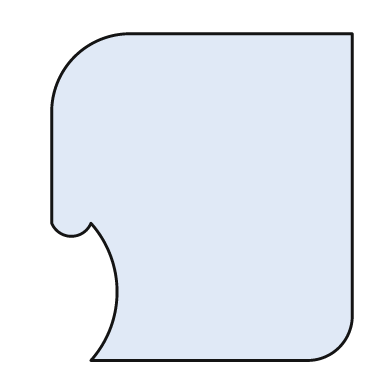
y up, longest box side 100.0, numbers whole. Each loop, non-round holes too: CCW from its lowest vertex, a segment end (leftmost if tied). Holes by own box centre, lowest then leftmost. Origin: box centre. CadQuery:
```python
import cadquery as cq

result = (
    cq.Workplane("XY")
    .moveTo(-34.0, -50.0)
    .lineTo(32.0, -50.0)
    .threePointArc((42.0, -46.0), (46.0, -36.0))
    .lineTo(46.0, 50.0)
    .lineTo(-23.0, 50.0)
    .threePointArc((-39.0, 43.0), (-46.0, 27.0))
    .lineTo(-46.0, -8.0)
    .threePointArc((-40.0, -12.0), (-34.0, -8.0))
    .threePointArc((-26.0, -29.0), (-34.0, -50.0))
    .close()
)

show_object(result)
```